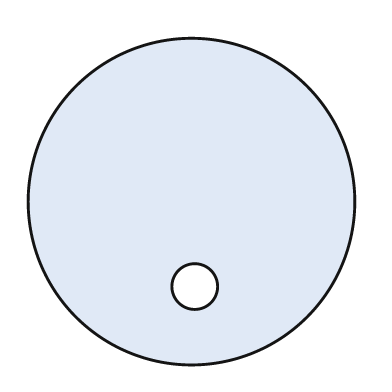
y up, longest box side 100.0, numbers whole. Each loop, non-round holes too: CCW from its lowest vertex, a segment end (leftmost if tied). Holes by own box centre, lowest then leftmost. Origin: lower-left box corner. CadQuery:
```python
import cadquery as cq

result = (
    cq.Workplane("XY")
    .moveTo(50.0, 50.0)
    .circle(50.0)
    .moveTo(51.0, 24.0)
    .circle(7.0)
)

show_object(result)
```